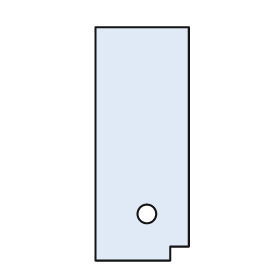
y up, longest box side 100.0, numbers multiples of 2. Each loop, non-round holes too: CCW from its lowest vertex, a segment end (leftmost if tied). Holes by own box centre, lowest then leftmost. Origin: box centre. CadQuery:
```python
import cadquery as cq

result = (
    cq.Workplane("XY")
    .moveTo(-20.0, -50.0)
    .lineTo(12.0, -50.0)
    .lineTo(12.0, -44.0)
    .lineTo(20.0, -44.0)
    .lineTo(20.0, 50.0)
    .lineTo(-20.0, 50.0)
    .close()
    .moveTo(2.0, -30.0)
    .circle(4.0)
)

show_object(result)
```